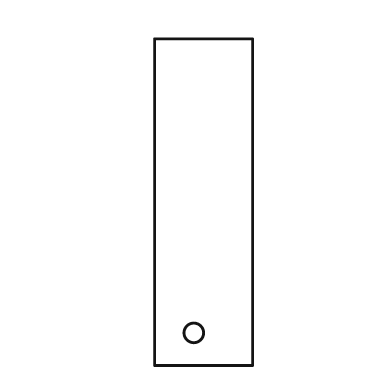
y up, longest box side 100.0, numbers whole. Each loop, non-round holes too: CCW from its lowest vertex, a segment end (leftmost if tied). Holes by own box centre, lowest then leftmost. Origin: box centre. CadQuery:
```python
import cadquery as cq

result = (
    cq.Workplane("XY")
    .moveTo(-15.0, -50.0)
    .lineTo(15.0, -50.0)
    .lineTo(15.0, 50.0)
    .lineTo(-15.0, 50.0)
    .close()
    .moveTo(-3.0, -40.0)
    .circle(3.0)
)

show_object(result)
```